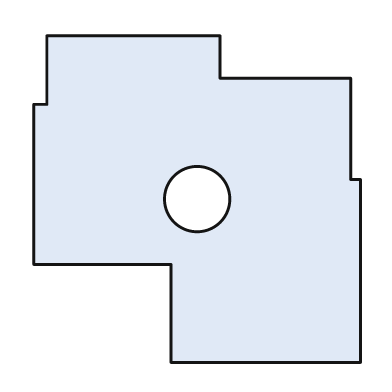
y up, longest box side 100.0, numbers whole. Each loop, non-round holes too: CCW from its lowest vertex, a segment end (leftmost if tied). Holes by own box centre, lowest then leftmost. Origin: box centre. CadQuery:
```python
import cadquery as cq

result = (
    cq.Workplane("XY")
    .moveTo(-8.0, -50.0)
    .lineTo(50.0, -50.0)
    .lineTo(50.0, 6.0)
    .lineTo(47.0, 6.0)
    .lineTo(47.0, 37.0)
    .lineTo(7.0, 37.0)
    .lineTo(7.0, 50.0)
    .lineTo(-46.0, 50.0)
    .lineTo(-46.0, 29.0)
    .lineTo(-50.0, 29.0)
    .lineTo(-50.0, -20.0)
    .lineTo(-8.0, -20.0)
    .close()
    .moveTo(0.0, 0.0)
    .circle(10.0)
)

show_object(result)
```